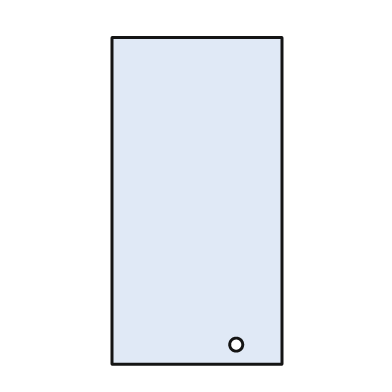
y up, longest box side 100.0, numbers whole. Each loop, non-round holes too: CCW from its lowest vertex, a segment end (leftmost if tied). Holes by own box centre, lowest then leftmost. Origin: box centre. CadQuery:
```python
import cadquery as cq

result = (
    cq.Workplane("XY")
    .moveTo(-26.0, -50.0)
    .lineTo(26.0, -50.0)
    .lineTo(26.0, 50.0)
    .lineTo(-26.0, 50.0)
    .close()
    .moveTo(12.0, -44.0)
    .circle(2.0)
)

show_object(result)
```